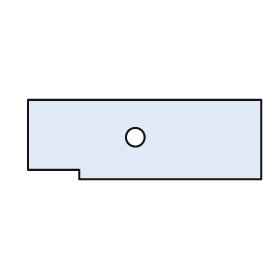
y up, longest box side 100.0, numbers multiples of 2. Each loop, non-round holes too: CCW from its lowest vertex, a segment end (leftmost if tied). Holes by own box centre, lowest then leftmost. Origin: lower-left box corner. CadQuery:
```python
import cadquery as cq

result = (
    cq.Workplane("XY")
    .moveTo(22.0, 0.0)
    .lineTo(100.0, 0.0)
    .lineTo(100.0, 34.0)
    .lineTo(0.0, 34.0)
    .lineTo(0.0, 4.0)
    .lineTo(22.0, 4.0)
    .close()
    .moveTo(46.0, 18.0)
    .circle(4.0)
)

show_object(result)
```